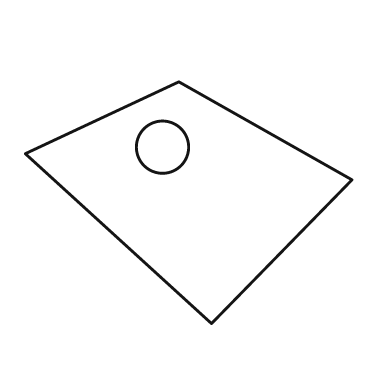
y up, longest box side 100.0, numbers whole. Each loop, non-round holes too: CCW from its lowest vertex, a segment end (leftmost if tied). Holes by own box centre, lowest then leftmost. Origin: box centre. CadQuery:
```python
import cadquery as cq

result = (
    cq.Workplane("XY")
    .moveTo(7.0, -37.0)
    .lineTo(50.0, 7.0)
    .lineTo(-3.0, 37.0)
    .lineTo(-50.0, 15.0)
    .close()
    .moveTo(-8.0, 17.0)
    .circle(8.0)
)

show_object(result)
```